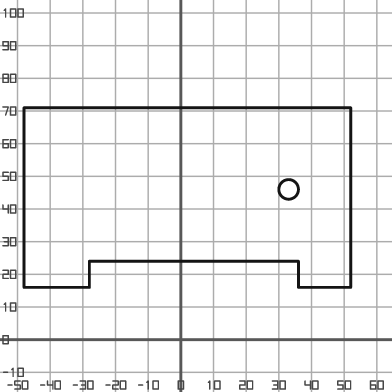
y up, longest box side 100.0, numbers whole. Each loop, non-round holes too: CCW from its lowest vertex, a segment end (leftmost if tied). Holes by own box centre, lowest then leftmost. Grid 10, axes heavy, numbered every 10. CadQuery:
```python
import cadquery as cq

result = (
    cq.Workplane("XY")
    .moveTo(-48.0, 16.0)
    .lineTo(-28.0, 16.0)
    .lineTo(-28.0, 24.0)
    .lineTo(36.0, 24.0)
    .lineTo(36.0, 16.0)
    .lineTo(52.0, 16.0)
    .lineTo(52.0, 71.0)
    .lineTo(-48.0, 71.0)
    .close()
    .moveTo(33.0, 46.0)
    .circle(3.0)
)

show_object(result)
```